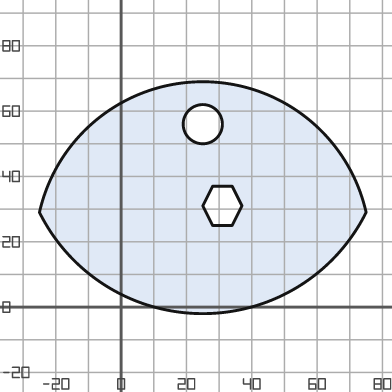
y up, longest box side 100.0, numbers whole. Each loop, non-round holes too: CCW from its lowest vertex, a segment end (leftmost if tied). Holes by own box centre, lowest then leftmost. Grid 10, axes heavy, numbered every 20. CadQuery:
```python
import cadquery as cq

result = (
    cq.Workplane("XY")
    .moveTo(-25.0, 29.0)
    .threePointArc((25.0, -2.0), (75.0, 29.0))
    .threePointArc((25.0, 69.0), (-25.0, 29.0))
    .close()
    .moveTo(28.0, 25.0)
    .lineTo(34.0, 25.0)
    .lineTo(37.0, 31.0)
    .lineTo(34.0, 37.0)
    .lineTo(28.0, 37.0)
    .lineTo(25.0, 31.0)
    .close()
    .moveTo(25.0, 56.0)
    .circle(6.0)
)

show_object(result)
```